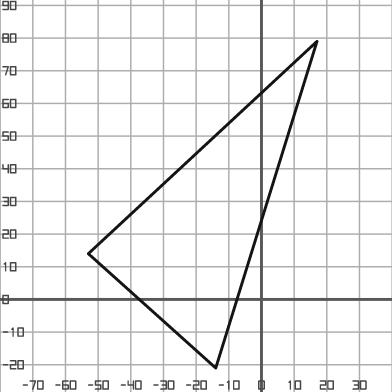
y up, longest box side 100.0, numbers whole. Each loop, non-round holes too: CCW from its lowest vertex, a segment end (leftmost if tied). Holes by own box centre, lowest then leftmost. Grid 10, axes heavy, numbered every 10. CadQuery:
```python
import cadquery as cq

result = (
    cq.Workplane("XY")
    .moveTo(-14.0, -21.0)
    .lineTo(17.0, 79.0)
    .lineTo(-53.0, 14.0)
    .close()
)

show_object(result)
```